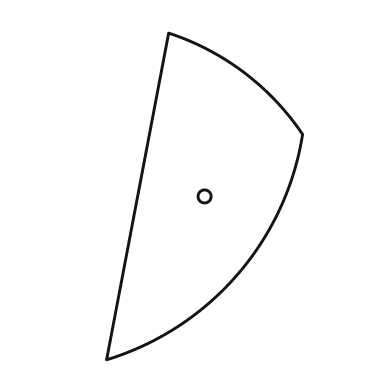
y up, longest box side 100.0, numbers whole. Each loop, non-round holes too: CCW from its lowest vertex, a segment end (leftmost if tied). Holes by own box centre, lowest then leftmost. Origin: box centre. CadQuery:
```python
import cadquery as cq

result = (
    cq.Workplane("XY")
    .moveTo(-30.0, -50.0)
    .threePointArc((10.0, -24.0), (30.0, 19.0))
    .threePointArc((12.0, 38.0), (-11.0, 50.0))
    .close()
    .moveTo(0.0, 0.0)
    .circle(2.0)
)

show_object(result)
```